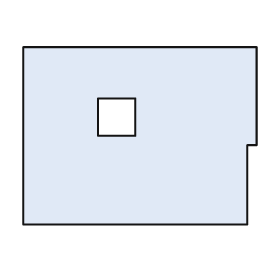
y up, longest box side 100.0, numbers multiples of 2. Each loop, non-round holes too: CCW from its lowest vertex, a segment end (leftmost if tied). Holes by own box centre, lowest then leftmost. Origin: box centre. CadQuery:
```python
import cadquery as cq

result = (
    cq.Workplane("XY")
    .moveTo(-50.0, -38.0)
    .lineTo(46.0, -38.0)
    .lineTo(46.0, -4.0)
    .lineTo(50.0, -4.0)
    .lineTo(50.0, 38.0)
    .lineTo(-50.0, 38.0)
    .close()
    .moveTo(-18.0, 0.0)
    .lineTo(-2.0, 0.0)
    .lineTo(-2.0, 16.0)
    .lineTo(-18.0, 16.0)
    .close()
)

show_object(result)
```